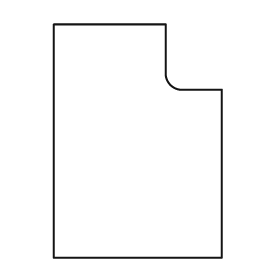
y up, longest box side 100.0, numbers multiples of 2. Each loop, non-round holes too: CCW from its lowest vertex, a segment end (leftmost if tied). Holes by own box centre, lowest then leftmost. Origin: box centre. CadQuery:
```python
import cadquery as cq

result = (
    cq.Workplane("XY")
    .moveTo(-36.0, -50.0)
    .lineTo(36.0, -50.0)
    .lineTo(36.0, 22.0)
    .lineTo(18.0, 22.0)
    .threePointArc((14.0, 24.0), (12.0, 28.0))
    .lineTo(12.0, 50.0)
    .lineTo(-36.0, 50.0)
    .close()
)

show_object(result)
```